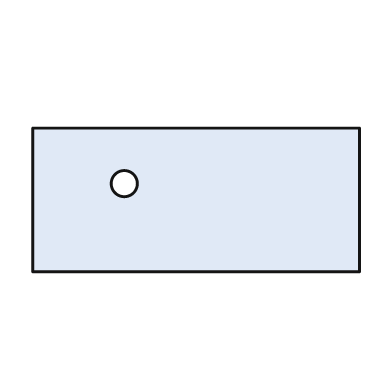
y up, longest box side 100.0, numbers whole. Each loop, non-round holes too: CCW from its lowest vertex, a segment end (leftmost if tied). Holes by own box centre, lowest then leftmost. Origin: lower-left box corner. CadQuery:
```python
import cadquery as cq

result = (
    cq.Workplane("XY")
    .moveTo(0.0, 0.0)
    .lineTo(100.0, 0.0)
    .lineTo(100.0, 44.0)
    .lineTo(0.0, 44.0)
    .close()
    .moveTo(28.0, 27.0)
    .circle(4.0)
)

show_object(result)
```